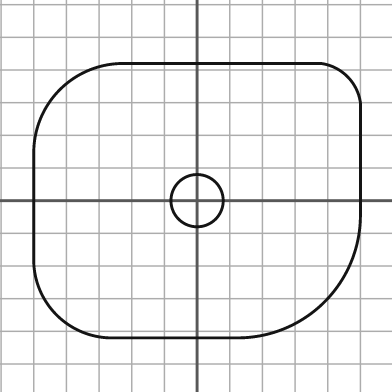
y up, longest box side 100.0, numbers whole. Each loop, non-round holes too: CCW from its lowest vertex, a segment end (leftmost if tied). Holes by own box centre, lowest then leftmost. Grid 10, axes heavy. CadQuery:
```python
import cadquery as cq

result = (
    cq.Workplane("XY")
    .moveTo(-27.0, -42.0)
    .lineTo(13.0, -42.0)
    .threePointArc((39.0, -31.0), (50.0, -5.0))
    .lineTo(50.0, 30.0)
    .threePointArc((46.0, 38.0), (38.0, 42.0))
    .lineTo(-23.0, 42.0)
    .threePointArc((-42.0, 34.0), (-50.0, 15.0))
    .lineTo(-50.0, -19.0)
    .threePointArc((-43.0, -35.0), (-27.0, -42.0))
    .close()
    .moveTo(0.0, 0.0)
    .circle(8.0)
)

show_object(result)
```